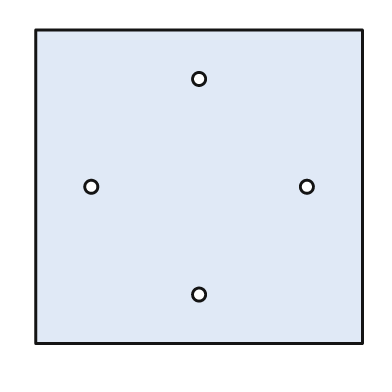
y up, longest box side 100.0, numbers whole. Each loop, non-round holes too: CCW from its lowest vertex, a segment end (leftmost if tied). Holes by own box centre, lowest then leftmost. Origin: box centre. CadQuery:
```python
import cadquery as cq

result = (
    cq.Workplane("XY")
    .moveTo(-50.0, -48.0)
    .lineTo(50.0, -48.0)
    .lineTo(50.0, 48.0)
    .lineTo(-50.0, 48.0)
    .close()
    .moveTo(0.0, -33.0)
    .circle(2.0)
    .moveTo(-33.0, 0.0)
    .circle(2.0)
    .moveTo(33.0, 0.0)
    .circle(2.0)
    .moveTo(0.0, 33.0)
    .circle(2.0)
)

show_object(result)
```